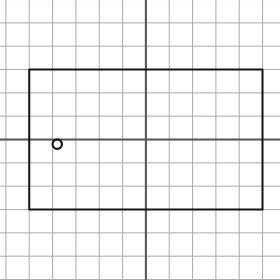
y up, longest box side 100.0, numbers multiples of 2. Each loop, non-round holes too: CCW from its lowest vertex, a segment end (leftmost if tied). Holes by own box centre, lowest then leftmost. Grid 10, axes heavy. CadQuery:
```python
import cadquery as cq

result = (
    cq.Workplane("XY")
    .moveTo(-50.0, -30.0)
    .lineTo(50.0, -30.0)
    .lineTo(50.0, 30.0)
    .lineTo(-50.0, 30.0)
    .close()
    .moveTo(-38.0, -2.0)
    .circle(2.0)
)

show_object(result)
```